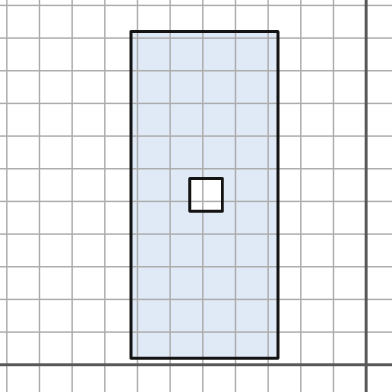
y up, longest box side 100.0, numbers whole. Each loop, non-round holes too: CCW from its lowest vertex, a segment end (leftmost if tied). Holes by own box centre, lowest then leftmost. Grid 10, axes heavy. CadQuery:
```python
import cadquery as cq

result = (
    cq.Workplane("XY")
    .moveTo(-72.0, 2.0)
    .lineTo(-27.0, 2.0)
    .lineTo(-27.0, 102.0)
    .lineTo(-72.0, 102.0)
    .close()
    .moveTo(-54.0, 47.0)
    .lineTo(-44.0, 47.0)
    .lineTo(-44.0, 57.0)
    .lineTo(-54.0, 57.0)
    .close()
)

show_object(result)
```